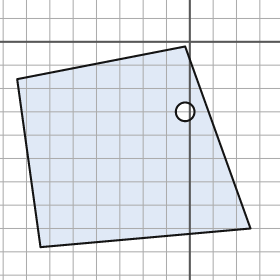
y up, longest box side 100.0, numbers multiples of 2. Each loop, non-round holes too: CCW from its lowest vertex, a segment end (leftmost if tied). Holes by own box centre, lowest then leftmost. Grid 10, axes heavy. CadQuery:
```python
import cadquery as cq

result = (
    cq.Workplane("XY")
    .moveTo(-64.0, -88.0)
    .lineTo(26.0, -80.0)
    .lineTo(-2.0, -2.0)
    .lineTo(-74.0, -16.0)
    .close()
    .moveTo(-2.0, -30.0)
    .circle(4.0)
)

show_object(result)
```